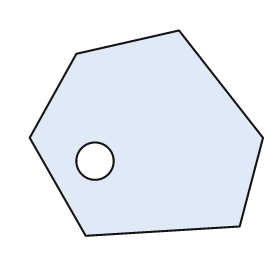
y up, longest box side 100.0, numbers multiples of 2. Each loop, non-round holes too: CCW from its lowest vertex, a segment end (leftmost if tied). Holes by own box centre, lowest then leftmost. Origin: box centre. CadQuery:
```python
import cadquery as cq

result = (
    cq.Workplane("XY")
    .moveTo(-26.0, -44.0)
    .lineTo(40.0, -40.0)
    .lineTo(50.0, -2.0)
    .lineTo(14.0, 44.0)
    .lineTo(-30.0, 34.0)
    .lineTo(-50.0, -2.0)
    .close()
    .moveTo(-22.0, -12.0)
    .circle(8.0)
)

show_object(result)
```